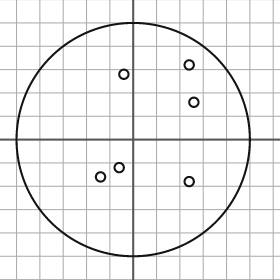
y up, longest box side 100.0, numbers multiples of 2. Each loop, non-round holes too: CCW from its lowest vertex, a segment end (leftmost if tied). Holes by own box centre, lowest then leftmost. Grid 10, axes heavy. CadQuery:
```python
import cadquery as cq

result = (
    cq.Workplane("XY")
    .moveTo(0.0, 0.0)
    .circle(50.0)
    .moveTo(24.0, -18.0)
    .circle(2.0)
    .moveTo(-14.0, -16.0)
    .circle(2.0)
    .moveTo(-6.0, -12.0)
    .circle(2.0)
    .moveTo(26.0, 16.0)
    .circle(2.0)
    .moveTo(-4.0, 28.0)
    .circle(2.0)
    .moveTo(24.0, 32.0)
    .circle(2.0)
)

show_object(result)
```